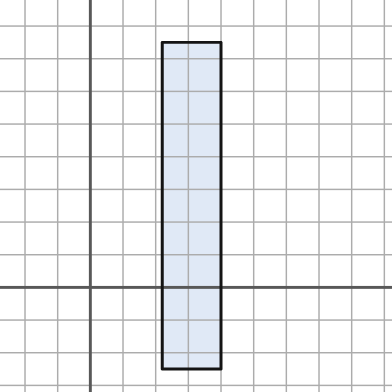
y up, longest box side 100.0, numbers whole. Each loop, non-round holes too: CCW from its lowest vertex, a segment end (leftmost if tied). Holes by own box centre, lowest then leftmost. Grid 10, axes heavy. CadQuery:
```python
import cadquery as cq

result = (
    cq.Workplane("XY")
    .moveTo(22.0, -25.0)
    .lineTo(40.0, -25.0)
    .lineTo(40.0, 75.0)
    .lineTo(22.0, 75.0)
    .close()
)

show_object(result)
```